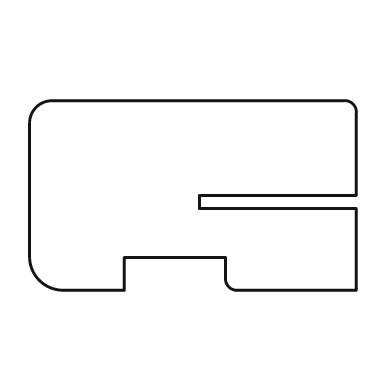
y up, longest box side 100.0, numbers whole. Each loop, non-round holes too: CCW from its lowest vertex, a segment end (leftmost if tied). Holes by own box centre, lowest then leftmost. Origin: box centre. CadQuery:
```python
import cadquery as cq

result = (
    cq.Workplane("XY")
    .moveTo(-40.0, -29.0)
    .lineTo(-21.0, -29.0)
    .lineTo(-21.0, -19.0)
    .lineTo(10.0, -19.0)
    .lineTo(10.0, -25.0)
    .threePointArc((11.0, -28.0), (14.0, -29.0))
    .lineTo(50.0, -29.0)
    .lineTo(50.0, -4.0)
    .lineTo(2.0, -4.0)
    .lineTo(2.0, 0.0)
    .lineTo(50.0, 0.0)
    .lineTo(50.0, 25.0)
    .threePointArc((49.0, 28.0), (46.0, 29.0))
    .lineTo(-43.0, 29.0)
    .threePointArc((-48.0, 27.0), (-50.0, 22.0))
    .lineTo(-50.0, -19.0)
    .threePointArc((-47.0, -26.0), (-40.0, -29.0))
    .close()
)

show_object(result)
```